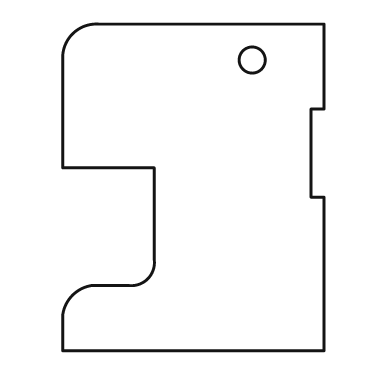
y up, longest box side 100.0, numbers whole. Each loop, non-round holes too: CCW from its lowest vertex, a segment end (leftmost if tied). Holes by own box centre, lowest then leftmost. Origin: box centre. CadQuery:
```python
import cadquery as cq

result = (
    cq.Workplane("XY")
    .moveTo(-40.0, -50.0)
    .lineTo(40.0, -50.0)
    .lineTo(40.0, -3.0)
    .lineTo(36.0, -3.0)
    .lineTo(36.0, 24.0)
    .lineTo(40.0, 24.0)
    .lineTo(40.0, 50.0)
    .lineTo(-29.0, 50.0)
    .threePointArc((-37.0, 47.0), (-40.0, 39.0))
    .lineTo(-40.0, 6.0)
    .lineTo(-12.0, 6.0)
    .lineTo(-12.0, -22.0)
    .threePointArc((-14.0, -28.0), (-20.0, -30.0))
    .lineTo(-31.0, -30.0)
    .threePointArc((-37.0, -33.0), (-40.0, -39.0))
    .close()
    .moveTo(18.0, 39.0)
    .circle(4.0)
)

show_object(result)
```